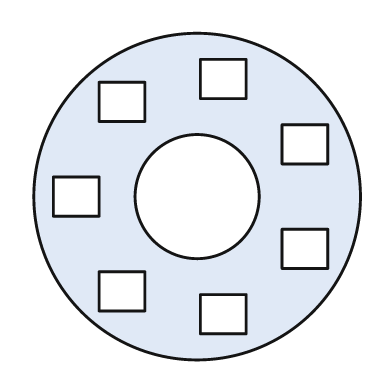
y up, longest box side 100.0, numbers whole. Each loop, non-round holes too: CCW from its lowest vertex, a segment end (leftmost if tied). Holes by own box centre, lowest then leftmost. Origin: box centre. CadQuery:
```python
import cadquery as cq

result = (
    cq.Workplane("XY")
    .moveTo(0.0, 0.0)
    .circle(50.0)
    .moveTo(1.0, -42.0)
    .lineTo(15.0, -42.0)
    .lineTo(15.0, -30.0)
    .lineTo(1.0, -30.0)
    .close()
    .moveTo(-30.0, -35.0)
    .lineTo(-16.0, -35.0)
    .lineTo(-16.0, -23.0)
    .lineTo(-30.0, -23.0)
    .close()
    .moveTo(26.0, -22.0)
    .lineTo(40.0, -22.0)
    .lineTo(40.0, -10.0)
    .lineTo(26.0, -10.0)
    .close()
    .moveTo(-44.0, -6.0)
    .lineTo(-30.0, -6.0)
    .lineTo(-30.0, 6.0)
    .lineTo(-44.0, 6.0)
    .close()
    .moveTo(0.0, 0.0)
    .circle(19.0)
    .moveTo(26.0, 10.0)
    .lineTo(40.0, 10.0)
    .lineTo(40.0, 22.0)
    .lineTo(26.0, 22.0)
    .close()
    .moveTo(-30.0, 23.0)
    .lineTo(-16.0, 23.0)
    .lineTo(-16.0, 35.0)
    .lineTo(-30.0, 35.0)
    .close()
    .moveTo(1.0, 30.0)
    .lineTo(15.0, 30.0)
    .lineTo(15.0, 42.0)
    .lineTo(1.0, 42.0)
    .close()
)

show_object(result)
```